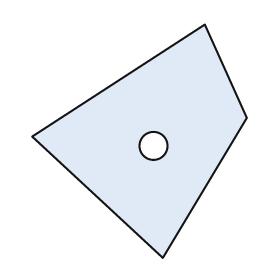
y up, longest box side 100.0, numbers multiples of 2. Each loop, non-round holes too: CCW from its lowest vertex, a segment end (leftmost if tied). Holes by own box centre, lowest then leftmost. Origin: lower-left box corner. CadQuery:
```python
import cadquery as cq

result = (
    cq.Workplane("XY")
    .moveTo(56.0, 0.0)
    .lineTo(92.0, 60.0)
    .lineTo(74.0, 100.0)
    .lineTo(0.0, 52.0)
    .close()
    .moveTo(52.0, 48.0)
    .circle(6.0)
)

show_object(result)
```